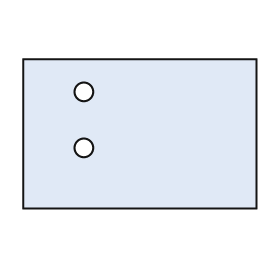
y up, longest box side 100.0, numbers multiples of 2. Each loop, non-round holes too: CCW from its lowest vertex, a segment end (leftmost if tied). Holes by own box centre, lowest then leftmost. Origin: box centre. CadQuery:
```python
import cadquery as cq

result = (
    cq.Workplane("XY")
    .moveTo(-50.0, -32.0)
    .lineTo(50.0, -32.0)
    .lineTo(50.0, 32.0)
    .lineTo(-50.0, 32.0)
    .close()
    .moveTo(-24.0, -6.0)
    .circle(4.0)
    .moveTo(-24.0, 18.0)
    .circle(4.0)
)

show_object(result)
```